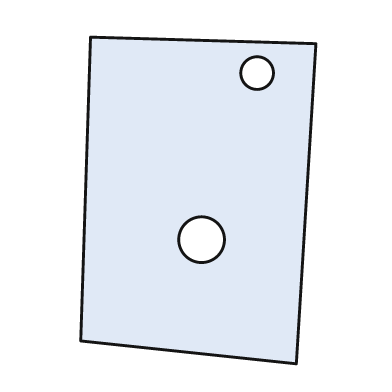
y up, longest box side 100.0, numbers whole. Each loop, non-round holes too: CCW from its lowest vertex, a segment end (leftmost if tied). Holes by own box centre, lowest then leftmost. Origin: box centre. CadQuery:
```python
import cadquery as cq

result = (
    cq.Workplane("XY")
    .moveTo(30.0, -50.0)
    .lineTo(36.0, 48.0)
    .lineTo(-33.0, 50.0)
    .lineTo(-36.0, -43.0)
    .close()
    .moveTo(1.0, -12.0)
    .circle(7.0)
    .moveTo(18.0, 39.0)
    .circle(5.0)
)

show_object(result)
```